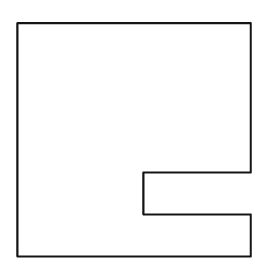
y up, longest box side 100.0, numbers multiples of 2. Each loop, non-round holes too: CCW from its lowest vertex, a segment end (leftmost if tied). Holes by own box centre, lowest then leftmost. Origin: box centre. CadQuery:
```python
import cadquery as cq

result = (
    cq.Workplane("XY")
    .moveTo(-50.0, -50.0)
    .lineTo(50.0, -50.0)
    .lineTo(50.0, -32.0)
    .lineTo(4.0, -32.0)
    .lineTo(4.0, -14.0)
    .lineTo(50.0, -14.0)
    .lineTo(50.0, 50.0)
    .lineTo(-50.0, 50.0)
    .close()
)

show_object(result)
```